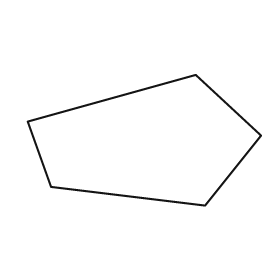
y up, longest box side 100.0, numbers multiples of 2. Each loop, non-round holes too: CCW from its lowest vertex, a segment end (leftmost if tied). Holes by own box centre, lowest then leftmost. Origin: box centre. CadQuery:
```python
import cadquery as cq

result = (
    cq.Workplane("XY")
    .moveTo(26.0, -28.0)
    .lineTo(50.0, 2.0)
    .lineTo(22.0, 28.0)
    .lineTo(-50.0, 8.0)
    .lineTo(-40.0, -20.0)
    .close()
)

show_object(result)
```